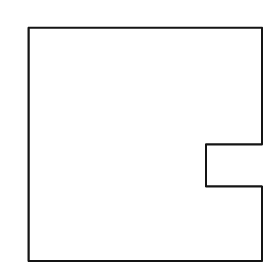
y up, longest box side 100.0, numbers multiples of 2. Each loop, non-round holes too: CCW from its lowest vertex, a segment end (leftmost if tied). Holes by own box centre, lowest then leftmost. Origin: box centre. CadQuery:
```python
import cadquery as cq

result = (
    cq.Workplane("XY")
    .moveTo(-50.0, -50.0)
    .lineTo(50.0, -50.0)
    .lineTo(50.0, -18.0)
    .lineTo(26.0, -18.0)
    .lineTo(26.0, 0.0)
    .lineTo(50.0, 0.0)
    .lineTo(50.0, 50.0)
    .lineTo(-50.0, 50.0)
    .close()
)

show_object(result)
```